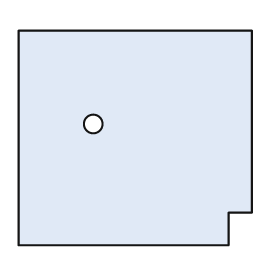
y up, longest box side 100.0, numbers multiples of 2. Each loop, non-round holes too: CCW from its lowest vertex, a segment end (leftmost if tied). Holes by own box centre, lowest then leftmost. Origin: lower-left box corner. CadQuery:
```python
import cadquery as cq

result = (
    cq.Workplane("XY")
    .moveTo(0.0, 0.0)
    .lineTo(90.0, 0.0)
    .lineTo(90.0, 14.0)
    .lineTo(100.0, 14.0)
    .lineTo(100.0, 92.0)
    .lineTo(0.0, 92.0)
    .close()
    .moveTo(32.0, 52.0)
    .circle(4.0)
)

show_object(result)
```